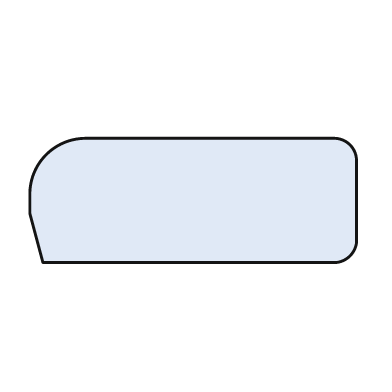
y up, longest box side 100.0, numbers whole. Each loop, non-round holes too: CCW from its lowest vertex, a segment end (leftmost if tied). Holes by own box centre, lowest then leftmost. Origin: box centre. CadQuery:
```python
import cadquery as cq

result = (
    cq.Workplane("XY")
    .moveTo(-46.0, -19.0)
    .lineTo(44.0, -19.0)
    .threePointArc((48.0, -17.0), (50.0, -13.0))
    .lineTo(50.0, 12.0)
    .threePointArc((48.0, 17.0), (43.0, 19.0))
    .lineTo(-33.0, 19.0)
    .threePointArc((-45.0, 14.0), (-50.0, 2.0))
    .lineTo(-50.0, -4.0)
    .close()
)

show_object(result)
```